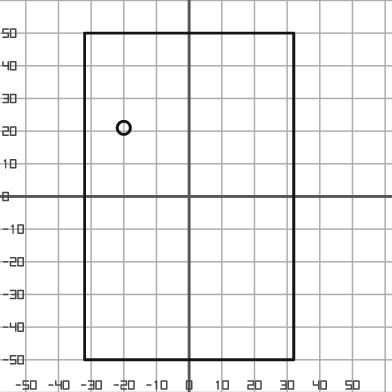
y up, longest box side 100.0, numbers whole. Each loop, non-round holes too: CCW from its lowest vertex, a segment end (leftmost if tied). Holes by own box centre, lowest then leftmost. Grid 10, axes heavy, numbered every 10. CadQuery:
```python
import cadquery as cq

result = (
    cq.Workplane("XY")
    .moveTo(-32.0, -50.0)
    .lineTo(32.0, -50.0)
    .lineTo(32.0, 50.0)
    .lineTo(-32.0, 50.0)
    .close()
    .moveTo(-20.0, 21.0)
    .circle(2.0)
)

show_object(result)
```